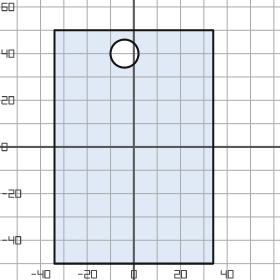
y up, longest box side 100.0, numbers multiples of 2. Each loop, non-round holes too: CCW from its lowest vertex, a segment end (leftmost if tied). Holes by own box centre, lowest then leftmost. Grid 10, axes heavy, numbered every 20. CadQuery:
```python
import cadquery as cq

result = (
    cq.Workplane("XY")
    .moveTo(-34.0, -50.0)
    .lineTo(34.0, -50.0)
    .lineTo(34.0, 50.0)
    .lineTo(-34.0, 50.0)
    .close()
    .moveTo(-4.0, 40.0)
    .circle(6.0)
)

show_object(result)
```